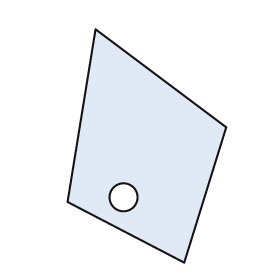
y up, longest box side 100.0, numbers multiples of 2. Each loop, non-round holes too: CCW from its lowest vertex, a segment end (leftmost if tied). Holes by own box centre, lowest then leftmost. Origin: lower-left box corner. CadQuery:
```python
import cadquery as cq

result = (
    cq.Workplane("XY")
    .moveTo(50.0, 0.0)
    .lineTo(68.0, 58.0)
    .lineTo(12.0, 100.0)
    .lineTo(0.0, 26.0)
    .close()
    .moveTo(24.0, 28.0)
    .circle(6.0)
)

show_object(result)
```